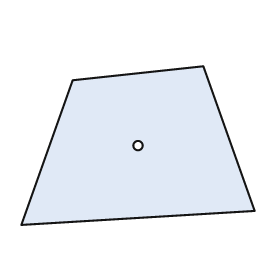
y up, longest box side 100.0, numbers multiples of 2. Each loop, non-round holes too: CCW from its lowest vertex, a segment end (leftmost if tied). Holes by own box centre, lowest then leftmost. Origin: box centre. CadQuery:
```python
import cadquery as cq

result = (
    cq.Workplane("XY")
    .moveTo(-50.0, -34.0)
    .lineTo(50.0, -28.0)
    .lineTo(28.0, 34.0)
    .lineTo(-28.0, 28.0)
    .close()
    .moveTo(0.0, 0.0)
    .circle(2.0)
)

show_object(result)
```